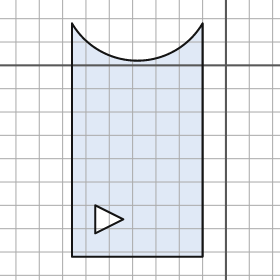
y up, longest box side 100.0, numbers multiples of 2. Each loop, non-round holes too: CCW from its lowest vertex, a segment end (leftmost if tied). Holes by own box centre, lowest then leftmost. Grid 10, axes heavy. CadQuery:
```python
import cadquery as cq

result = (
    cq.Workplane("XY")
    .moveTo(-66.0, -82.0)
    .lineTo(-10.0, -82.0)
    .lineTo(-10.0, 18.0)
    .threePointArc((-38.0, 2.0), (-66.0, 18.0))
    .close()
    .moveTo(-56.0, -72.0)
    .lineTo(-44.0, -66.0)
    .lineTo(-56.0, -60.0)
    .close()
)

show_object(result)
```